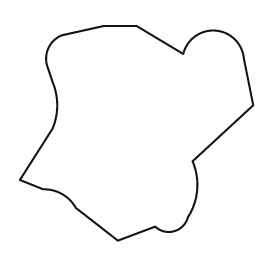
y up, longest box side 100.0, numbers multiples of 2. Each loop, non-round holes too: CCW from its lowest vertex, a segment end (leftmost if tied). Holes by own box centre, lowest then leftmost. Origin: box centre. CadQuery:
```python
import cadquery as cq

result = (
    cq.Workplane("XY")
    .moveTo(-8.0, -46.0)
    .lineTo(8.0, -40.0)
    .threePointArc((16.0, -42.0), (22.0, -36.0))
    .threePointArc((26.0, -24.0), (24.0, -12.0))
    .lineTo(50.0, 12.0)
    .lineTo(46.0, 32.0)
    .threePointArc((34.0, 44.0), (20.0, 34.0))
    .lineTo(0.0, 46.0)
    .lineTo(-14.0, 46.0)
    .lineTo(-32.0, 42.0)
    .threePointArc((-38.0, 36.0), (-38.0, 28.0))
    .lineTo(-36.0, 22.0)
    .threePointArc((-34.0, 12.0), (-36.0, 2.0))
    .lineTo(-50.0, -20.0)
    .lineTo(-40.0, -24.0)
    .threePointArc((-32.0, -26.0), (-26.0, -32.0))
    .close()
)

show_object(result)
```